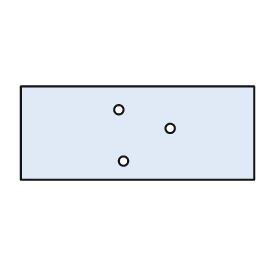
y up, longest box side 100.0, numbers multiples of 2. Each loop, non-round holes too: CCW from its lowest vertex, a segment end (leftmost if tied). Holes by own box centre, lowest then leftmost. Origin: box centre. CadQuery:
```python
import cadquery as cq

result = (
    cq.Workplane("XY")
    .moveTo(-50.0, -20.0)
    .lineTo(50.0, -20.0)
    .lineTo(50.0, 20.0)
    .lineTo(-50.0, 20.0)
    .close()
    .moveTo(-6.0, -12.0)
    .circle(2.0)
    .moveTo(14.0, 2.0)
    .circle(2.0)
    .moveTo(-8.0, 10.0)
    .circle(2.0)
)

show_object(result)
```